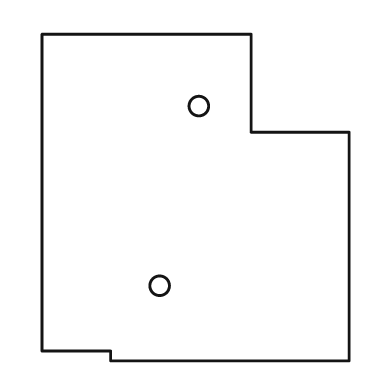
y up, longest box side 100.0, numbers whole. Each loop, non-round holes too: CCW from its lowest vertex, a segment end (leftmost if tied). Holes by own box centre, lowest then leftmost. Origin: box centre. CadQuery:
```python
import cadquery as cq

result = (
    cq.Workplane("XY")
    .moveTo(-26.0, -50.0)
    .lineTo(47.0, -50.0)
    .lineTo(47.0, 20.0)
    .lineTo(17.0, 20.0)
    .lineTo(17.0, 50.0)
    .lineTo(-47.0, 50.0)
    .lineTo(-47.0, -47.0)
    .lineTo(-26.0, -47.0)
    .close()
    .moveTo(-11.0, -27.0)
    .circle(3.0)
    .moveTo(1.0, 28.0)
    .circle(3.0)
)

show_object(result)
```